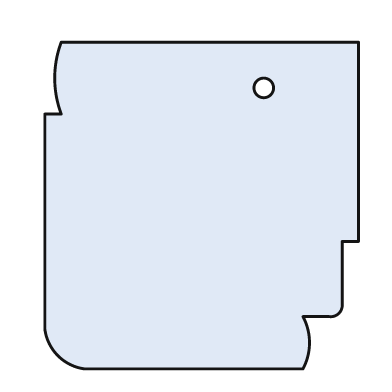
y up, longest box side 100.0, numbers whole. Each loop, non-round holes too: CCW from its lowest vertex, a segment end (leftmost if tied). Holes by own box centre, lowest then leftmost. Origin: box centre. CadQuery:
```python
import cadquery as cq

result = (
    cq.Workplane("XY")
    .moveTo(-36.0, -50.0)
    .lineTo(31.0, -50.0)
    .threePointArc((33.0, -42.0), (31.0, -34.0))
    .lineTo(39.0, -34.0)
    .threePointArc((42.0, -33.0), (43.0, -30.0))
    .lineTo(43.0, -11.0)
    .lineTo(48.0, -11.0)
    .lineTo(48.0, 50.0)
    .lineTo(-43.0, 50.0)
    .threePointArc((-45.0, 39.0), (-43.0, 28.0))
    .lineTo(-48.0, 28.0)
    .lineTo(-48.0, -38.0)
    .threePointArc((-44.0, -46.0), (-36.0, -50.0))
    .close()
    .moveTo(19.0, 36.0)
    .circle(3.0)
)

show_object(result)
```